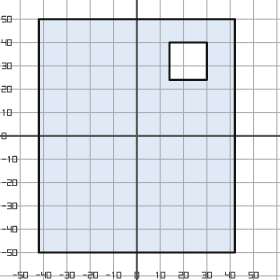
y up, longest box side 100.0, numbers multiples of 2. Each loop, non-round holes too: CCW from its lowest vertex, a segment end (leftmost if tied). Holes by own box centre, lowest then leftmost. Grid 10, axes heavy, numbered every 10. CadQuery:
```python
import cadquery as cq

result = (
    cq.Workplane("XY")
    .moveTo(-42.0, -50.0)
    .lineTo(42.0, -50.0)
    .lineTo(42.0, 50.0)
    .lineTo(-42.0, 50.0)
    .close()
    .moveTo(14.0, 24.0)
    .lineTo(30.0, 24.0)
    .lineTo(30.0, 40.0)
    .lineTo(14.0, 40.0)
    .close()
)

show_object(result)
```